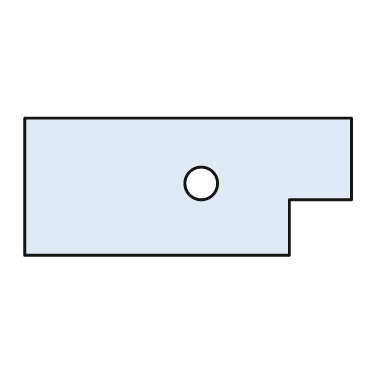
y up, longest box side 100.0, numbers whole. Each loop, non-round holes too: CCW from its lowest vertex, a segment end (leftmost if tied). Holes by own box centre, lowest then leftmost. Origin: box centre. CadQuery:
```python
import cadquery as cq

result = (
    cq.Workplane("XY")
    .moveTo(-50.0, -21.0)
    .lineTo(31.0, -21.0)
    .lineTo(31.0, -4.0)
    .lineTo(50.0, -4.0)
    .lineTo(50.0, 21.0)
    .lineTo(-50.0, 21.0)
    .close()
    .moveTo(4.0, 1.0)
    .circle(5.0)
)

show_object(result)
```